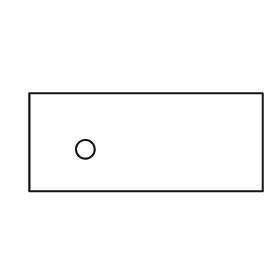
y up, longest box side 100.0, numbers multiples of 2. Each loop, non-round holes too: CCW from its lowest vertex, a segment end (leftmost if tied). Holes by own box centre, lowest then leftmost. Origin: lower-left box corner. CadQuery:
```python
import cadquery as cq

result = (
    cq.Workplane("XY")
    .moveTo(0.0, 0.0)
    .lineTo(100.0, 0.0)
    .lineTo(100.0, 42.0)
    .lineTo(0.0, 42.0)
    .close()
    .moveTo(24.0, 18.0)
    .circle(4.0)
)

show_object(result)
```